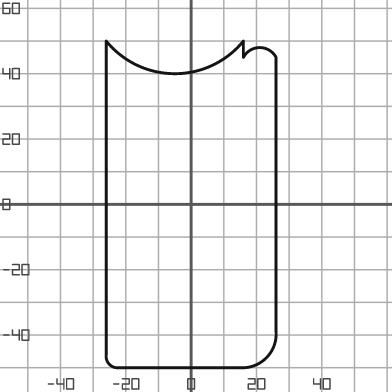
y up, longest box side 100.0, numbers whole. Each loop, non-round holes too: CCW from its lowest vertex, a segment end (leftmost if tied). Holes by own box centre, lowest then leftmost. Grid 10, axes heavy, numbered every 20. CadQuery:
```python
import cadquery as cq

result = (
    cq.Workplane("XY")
    .moveTo(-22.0, -50.0)
    .lineTo(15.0, -50.0)
    .threePointArc((23.0, -47.0), (26.0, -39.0))
    .lineTo(26.0, 45.0)
    .threePointArc((21.0, 48.0), (16.0, 45.0))
    .lineTo(16.0, 50.0)
    .threePointArc((-5.0, 40.0), (-26.0, 50.0))
    .lineTo(-26.0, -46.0)
    .threePointArc((-25.0, -49.0), (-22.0, -50.0))
    .close()
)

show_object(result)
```